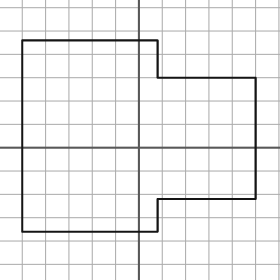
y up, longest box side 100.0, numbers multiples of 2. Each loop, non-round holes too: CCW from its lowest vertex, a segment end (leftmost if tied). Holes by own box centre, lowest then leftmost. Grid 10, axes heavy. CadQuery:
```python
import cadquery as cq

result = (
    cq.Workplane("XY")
    .moveTo(-50.0, -36.0)
    .lineTo(8.0, -36.0)
    .lineTo(8.0, -22.0)
    .lineTo(50.0, -22.0)
    .lineTo(50.0, 30.0)
    .lineTo(8.0, 30.0)
    .lineTo(8.0, 46.0)
    .lineTo(-50.0, 46.0)
    .close()
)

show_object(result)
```